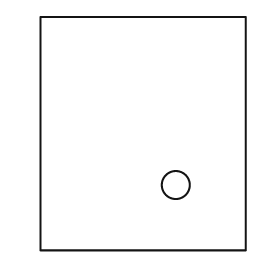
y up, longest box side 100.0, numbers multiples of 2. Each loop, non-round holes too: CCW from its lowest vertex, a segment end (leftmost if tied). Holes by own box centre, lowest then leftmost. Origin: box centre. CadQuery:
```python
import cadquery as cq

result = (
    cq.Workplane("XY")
    .moveTo(-44.0, -50.0)
    .lineTo(44.0, -50.0)
    .lineTo(44.0, 50.0)
    .lineTo(-44.0, 50.0)
    .close()
    .moveTo(14.0, -22.0)
    .circle(6.0)
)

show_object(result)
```